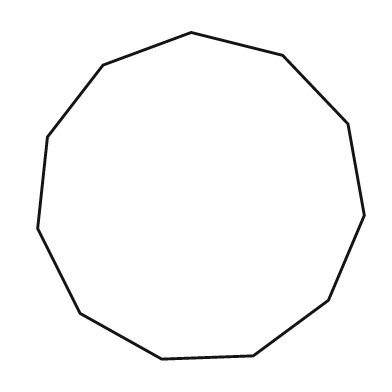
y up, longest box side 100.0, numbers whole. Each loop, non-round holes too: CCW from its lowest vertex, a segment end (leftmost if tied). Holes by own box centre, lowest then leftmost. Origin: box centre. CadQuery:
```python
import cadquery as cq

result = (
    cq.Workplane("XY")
    .moveTo(-12.0, -50.0)
    .lineTo(16.0, -49.0)
    .lineTo(39.0, -32.0)
    .lineTo(50.0, -6.0)
    .lineTo(45.0, 22.0)
    .lineTo(25.0, 43.0)
    .lineTo(-3.0, 50.0)
    .lineTo(-30.0, 40.0)
    .lineTo(-47.0, 18.0)
    .lineTo(-50.0, -10.0)
    .lineTo(-37.0, -36.0)
    .close()
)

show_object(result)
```